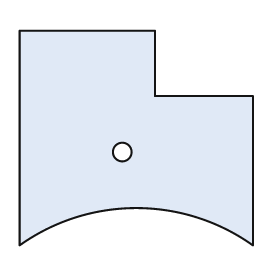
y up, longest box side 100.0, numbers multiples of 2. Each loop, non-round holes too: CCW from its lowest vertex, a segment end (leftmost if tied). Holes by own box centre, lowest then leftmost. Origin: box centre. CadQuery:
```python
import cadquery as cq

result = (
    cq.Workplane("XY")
    .moveTo(-50.0, -46.0)
    .threePointArc((0.0, -30.0), (50.0, -46.0))
    .lineTo(50.0, 18.0)
    .lineTo(8.0, 18.0)
    .lineTo(8.0, 46.0)
    .lineTo(-50.0, 46.0)
    .close()
    .moveTo(-6.0, -6.0)
    .circle(4.0)
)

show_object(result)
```